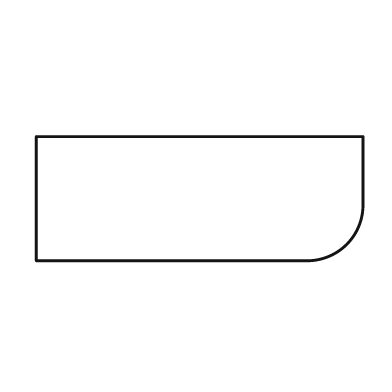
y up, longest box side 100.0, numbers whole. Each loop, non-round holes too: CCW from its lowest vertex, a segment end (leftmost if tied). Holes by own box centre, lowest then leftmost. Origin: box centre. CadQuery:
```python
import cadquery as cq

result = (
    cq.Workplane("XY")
    .moveTo(-50.0, -19.0)
    .lineTo(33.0, -19.0)
    .threePointArc((45.0, -14.0), (50.0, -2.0))
    .lineTo(50.0, 19.0)
    .lineTo(-50.0, 19.0)
    .close()
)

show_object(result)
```